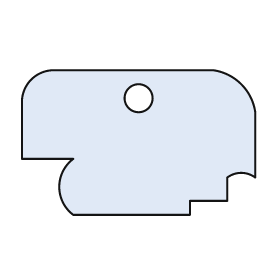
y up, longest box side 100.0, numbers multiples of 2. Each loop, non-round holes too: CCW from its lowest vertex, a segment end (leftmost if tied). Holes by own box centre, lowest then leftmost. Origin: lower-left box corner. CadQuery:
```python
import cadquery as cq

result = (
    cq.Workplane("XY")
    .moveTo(22.0, 0.0)
    .lineTo(72.0, 0.0)
    .lineTo(72.0, 6.0)
    .lineTo(88.0, 6.0)
    .lineTo(88.0, 16.0)
    .threePointArc((94.0, 18.0), (100.0, 16.0))
    .lineTo(100.0, 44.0)
    .threePointArc((94.0, 56.0), (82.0, 62.0))
    .lineTo(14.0, 62.0)
    .threePointArc((4.0, 58.0), (0.0, 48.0))
    .lineTo(0.0, 24.0)
    .lineTo(22.0, 24.0)
    .threePointArc((16.0, 12.0), (22.0, 0.0))
    .close()
    .moveTo(50.0, 50.0)
    .circle(6.0)
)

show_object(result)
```